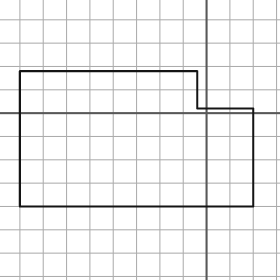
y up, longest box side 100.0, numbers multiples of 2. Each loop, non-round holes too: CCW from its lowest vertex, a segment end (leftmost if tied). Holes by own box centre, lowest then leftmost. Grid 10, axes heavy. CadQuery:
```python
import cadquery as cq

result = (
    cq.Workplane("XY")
    .moveTo(-80.0, -40.0)
    .lineTo(20.0, -40.0)
    .lineTo(20.0, 2.0)
    .lineTo(-4.0, 2.0)
    .lineTo(-4.0, 18.0)
    .lineTo(-80.0, 18.0)
    .close()
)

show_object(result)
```